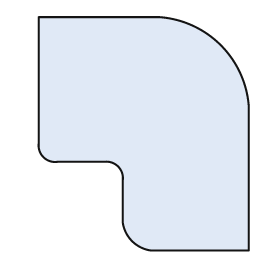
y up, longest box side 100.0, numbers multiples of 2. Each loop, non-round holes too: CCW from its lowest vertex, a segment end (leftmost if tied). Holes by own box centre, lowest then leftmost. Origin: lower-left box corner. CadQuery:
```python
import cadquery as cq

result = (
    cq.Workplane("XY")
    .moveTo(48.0, 0.0)
    .lineTo(90.0, 0.0)
    .lineTo(90.0, 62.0)
    .threePointArc((78.0, 88.0), (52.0, 100.0))
    .lineTo(0.0, 100.0)
    .lineTo(0.0, 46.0)
    .threePointArc((2.0, 40.0), (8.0, 38.0))
    .lineTo(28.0, 38.0)
    .threePointArc((34.0, 36.0), (36.0, 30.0))
    .lineTo(36.0, 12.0)
    .threePointArc((40.0, 4.0), (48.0, 0.0))
    .close()
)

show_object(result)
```